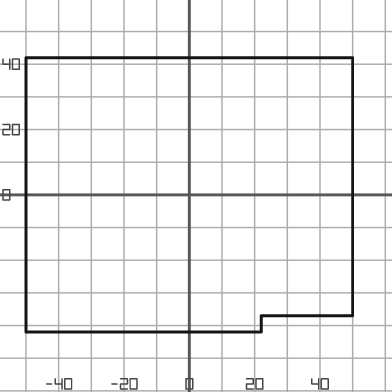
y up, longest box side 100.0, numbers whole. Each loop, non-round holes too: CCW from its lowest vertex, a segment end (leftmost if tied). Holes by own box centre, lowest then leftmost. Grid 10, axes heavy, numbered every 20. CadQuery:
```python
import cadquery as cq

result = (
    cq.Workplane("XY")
    .moveTo(-50.0, -42.0)
    .lineTo(22.0, -42.0)
    .lineTo(22.0, -37.0)
    .lineTo(50.0, -37.0)
    .lineTo(50.0, 42.0)
    .lineTo(-50.0, 42.0)
    .close()
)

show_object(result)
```